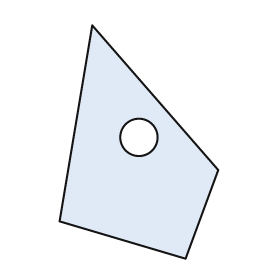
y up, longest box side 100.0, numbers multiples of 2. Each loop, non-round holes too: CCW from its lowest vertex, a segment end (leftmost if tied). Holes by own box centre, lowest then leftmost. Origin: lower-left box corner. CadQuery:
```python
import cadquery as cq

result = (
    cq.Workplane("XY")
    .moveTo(54.0, 0.0)
    .lineTo(68.0, 38.0)
    .lineTo(14.0, 100.0)
    .lineTo(0.0, 16.0)
    .close()
    .moveTo(34.0, 52.0)
    .circle(8.0)
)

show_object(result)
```